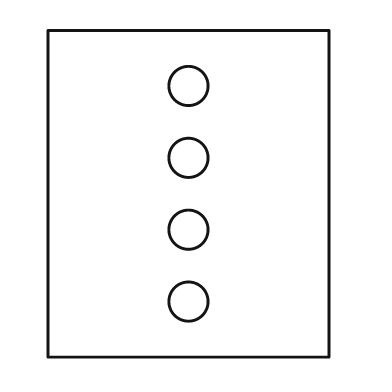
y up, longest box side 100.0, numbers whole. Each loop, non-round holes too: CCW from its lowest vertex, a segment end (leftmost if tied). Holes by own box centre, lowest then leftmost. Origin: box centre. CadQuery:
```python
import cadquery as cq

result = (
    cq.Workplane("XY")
    .moveTo(-43.0, -50.0)
    .lineTo(43.0, -50.0)
    .lineTo(43.0, 50.0)
    .lineTo(-43.0, 50.0)
    .close()
    .moveTo(0.0, -33.0)
    .circle(6.0)
    .moveTo(0.0, -11.0)
    .circle(6.0)
    .moveTo(0.0, 11.0)
    .circle(6.0)
    .moveTo(0.0, 33.0)
    .circle(6.0)
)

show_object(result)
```